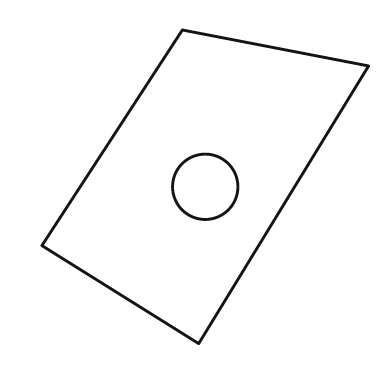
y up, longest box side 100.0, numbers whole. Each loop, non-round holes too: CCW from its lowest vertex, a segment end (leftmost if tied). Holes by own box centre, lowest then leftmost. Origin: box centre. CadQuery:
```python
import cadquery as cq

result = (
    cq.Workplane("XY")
    .moveTo(-2.0, -48.0)
    .lineTo(50.0, 37.0)
    .lineTo(-7.0, 48.0)
    .lineTo(-50.0, -18.0)
    .close()
    .moveTo(0.0, 0.0)
    .circle(10.0)
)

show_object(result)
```